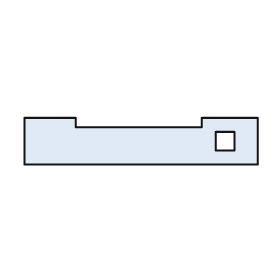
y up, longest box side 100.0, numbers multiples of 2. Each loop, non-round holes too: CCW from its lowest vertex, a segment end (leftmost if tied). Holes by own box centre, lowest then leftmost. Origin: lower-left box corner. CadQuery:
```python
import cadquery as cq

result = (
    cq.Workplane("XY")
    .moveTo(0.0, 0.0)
    .lineTo(100.0, 0.0)
    .lineTo(100.0, 20.0)
    .lineTo(76.0, 20.0)
    .lineTo(76.0, 16.0)
    .lineTo(22.0, 16.0)
    .lineTo(22.0, 20.0)
    .lineTo(0.0, 20.0)
    .close()
    .moveTo(82.0, 6.0)
    .lineTo(90.0, 6.0)
    .lineTo(90.0, 14.0)
    .lineTo(82.0, 14.0)
    .close()
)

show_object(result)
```